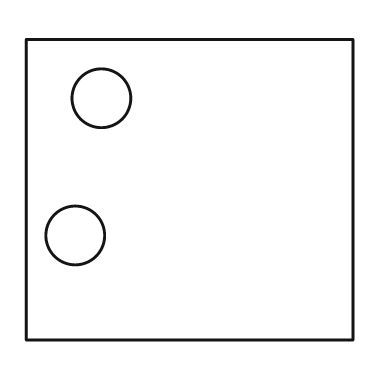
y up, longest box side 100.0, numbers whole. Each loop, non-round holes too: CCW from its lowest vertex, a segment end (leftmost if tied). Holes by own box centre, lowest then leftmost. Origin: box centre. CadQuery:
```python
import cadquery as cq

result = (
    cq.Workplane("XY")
    .moveTo(-50.0, -46.0)
    .lineTo(50.0, -46.0)
    .lineTo(50.0, 46.0)
    .lineTo(-50.0, 46.0)
    .close()
    .moveTo(-35.0, -14.0)
    .circle(9.0)
    .moveTo(-27.0, 28.0)
    .circle(9.0)
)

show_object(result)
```